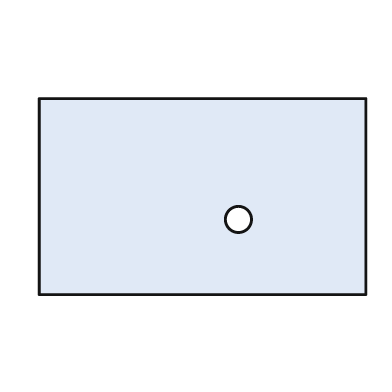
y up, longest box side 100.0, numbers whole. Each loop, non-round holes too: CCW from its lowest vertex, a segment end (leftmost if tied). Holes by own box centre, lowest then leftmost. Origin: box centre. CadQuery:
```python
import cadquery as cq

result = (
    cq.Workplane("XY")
    .moveTo(-50.0, -30.0)
    .lineTo(50.0, -30.0)
    .lineTo(50.0, 30.0)
    .lineTo(-50.0, 30.0)
    .close()
    .moveTo(11.0, -7.0)
    .circle(4.0)
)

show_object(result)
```